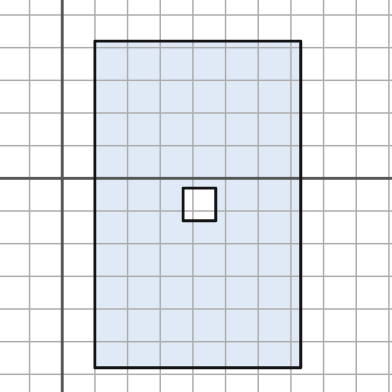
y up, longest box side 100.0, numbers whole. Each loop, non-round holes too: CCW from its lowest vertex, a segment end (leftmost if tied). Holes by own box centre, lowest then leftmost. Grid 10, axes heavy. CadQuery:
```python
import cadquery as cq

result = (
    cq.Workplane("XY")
    .moveTo(10.0, -58.0)
    .lineTo(73.0, -58.0)
    .lineTo(73.0, 42.0)
    .lineTo(10.0, 42.0)
    .close()
    .moveTo(37.0, -13.0)
    .lineTo(47.0, -13.0)
    .lineTo(47.0, -3.0)
    .lineTo(37.0, -3.0)
    .close()
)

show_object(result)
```